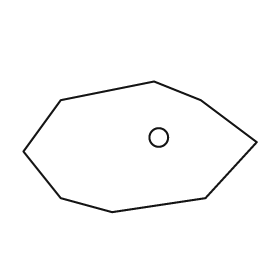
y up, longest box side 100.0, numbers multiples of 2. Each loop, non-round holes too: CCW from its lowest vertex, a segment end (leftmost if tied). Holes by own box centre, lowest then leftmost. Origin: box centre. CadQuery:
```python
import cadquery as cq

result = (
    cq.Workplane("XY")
    .moveTo(-12.0, -28.0)
    .lineTo(28.0, -22.0)
    .lineTo(50.0, 2.0)
    .lineTo(26.0, 20.0)
    .lineTo(6.0, 28.0)
    .lineTo(-34.0, 20.0)
    .lineTo(-50.0, -2.0)
    .lineTo(-34.0, -22.0)
    .close()
    .moveTo(8.0, 4.0)
    .circle(4.0)
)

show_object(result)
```